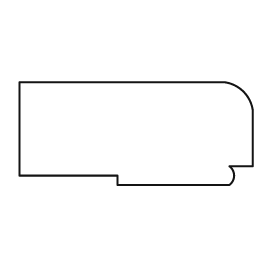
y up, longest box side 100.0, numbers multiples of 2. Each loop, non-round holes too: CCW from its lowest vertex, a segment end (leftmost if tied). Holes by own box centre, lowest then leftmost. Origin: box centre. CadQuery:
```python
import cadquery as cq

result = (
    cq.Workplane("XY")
    .moveTo(-8.0, -22.0)
    .lineTo(40.0, -22.0)
    .threePointArc((42.0, -18.0), (40.0, -14.0))
    .lineTo(50.0, -14.0)
    .lineTo(50.0, 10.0)
    .threePointArc((46.0, 18.0), (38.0, 22.0))
    .lineTo(-50.0, 22.0)
    .lineTo(-50.0, -18.0)
    .lineTo(-8.0, -18.0)
    .close()
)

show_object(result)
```